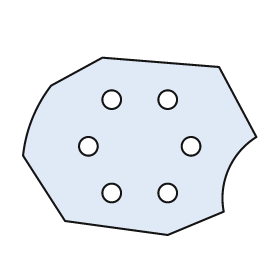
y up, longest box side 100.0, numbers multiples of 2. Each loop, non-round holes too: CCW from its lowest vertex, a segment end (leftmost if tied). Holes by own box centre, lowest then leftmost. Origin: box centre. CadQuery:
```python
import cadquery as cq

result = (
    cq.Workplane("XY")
    .moveTo(12.0, -38.0)
    .lineTo(36.0, -28.0)
    .threePointArc((38.0, -10.0), (50.0, 4.0))
    .lineTo(34.0, 34.0)
    .lineTo(-16.0, 38.0)
    .lineTo(-38.0, 26.0)
    .threePointArc((-46.0, 12.0), (-50.0, -4.0))
    .lineTo(-32.0, -32.0)
    .close()
    .moveTo(-12.0, -20.0)
    .circle(4.0)
    .moveTo(12.0, -20.0)
    .circle(4.0)
    .moveTo(-22.0, 0.0)
    .circle(4.0)
    .moveTo(22.0, 0.0)
    .circle(4.0)
    .moveTo(-12.0, 20.0)
    .circle(4.0)
    .moveTo(12.0, 20.0)
    .circle(4.0)
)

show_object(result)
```